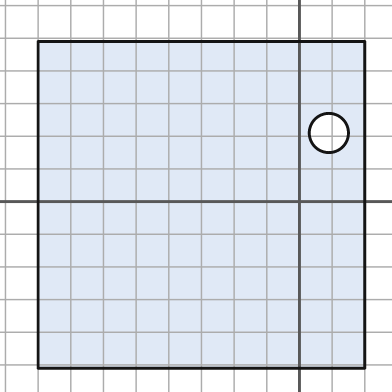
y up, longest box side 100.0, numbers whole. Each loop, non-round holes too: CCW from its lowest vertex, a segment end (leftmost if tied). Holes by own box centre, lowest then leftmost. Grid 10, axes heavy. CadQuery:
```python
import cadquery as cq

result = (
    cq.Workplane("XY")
    .moveTo(-80.0, -51.0)
    .lineTo(20.0, -51.0)
    .lineTo(20.0, 49.0)
    .lineTo(-80.0, 49.0)
    .close()
    .moveTo(9.0, 21.0)
    .circle(6.0)
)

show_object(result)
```